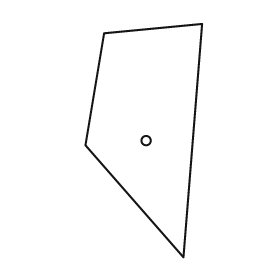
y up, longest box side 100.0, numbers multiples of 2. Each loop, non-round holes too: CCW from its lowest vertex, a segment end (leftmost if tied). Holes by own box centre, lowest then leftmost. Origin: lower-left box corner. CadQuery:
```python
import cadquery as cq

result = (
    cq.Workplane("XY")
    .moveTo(42.0, 0.0)
    .lineTo(50.0, 100.0)
    .lineTo(8.0, 96.0)
    .lineTo(0.0, 48.0)
    .close()
    .moveTo(26.0, 50.0)
    .circle(2.0)
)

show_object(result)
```